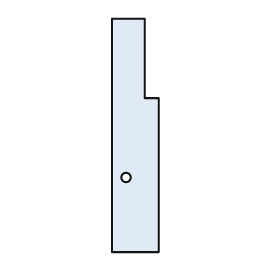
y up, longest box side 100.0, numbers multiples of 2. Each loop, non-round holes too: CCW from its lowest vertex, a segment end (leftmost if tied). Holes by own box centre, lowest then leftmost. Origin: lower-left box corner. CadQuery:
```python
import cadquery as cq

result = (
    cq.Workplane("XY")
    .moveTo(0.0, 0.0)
    .lineTo(20.0, 0.0)
    .lineTo(20.0, 66.0)
    .lineTo(14.0, 66.0)
    .lineTo(14.0, 100.0)
    .lineTo(0.0, 100.0)
    .close()
    .moveTo(6.0, 32.0)
    .circle(2.0)
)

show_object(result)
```